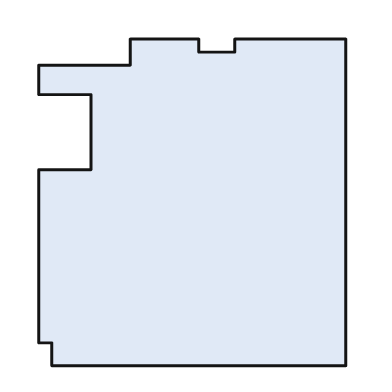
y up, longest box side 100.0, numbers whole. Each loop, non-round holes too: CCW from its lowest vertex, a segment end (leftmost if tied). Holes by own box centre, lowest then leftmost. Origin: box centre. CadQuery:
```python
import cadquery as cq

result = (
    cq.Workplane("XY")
    .moveTo(-43.0, -50.0)
    .lineTo(47.0, -50.0)
    .lineTo(47.0, 50.0)
    .lineTo(13.0, 50.0)
    .lineTo(13.0, 46.0)
    .lineTo(2.0, 46.0)
    .lineTo(2.0, 50.0)
    .lineTo(-19.0, 50.0)
    .lineTo(-19.0, 42.0)
    .lineTo(-47.0, 42.0)
    .lineTo(-47.0, 33.0)
    .lineTo(-31.0, 33.0)
    .lineTo(-31.0, 10.0)
    .lineTo(-47.0, 10.0)
    .lineTo(-47.0, -43.0)
    .lineTo(-43.0, -43.0)
    .close()
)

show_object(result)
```